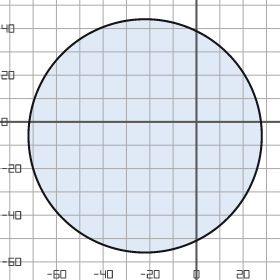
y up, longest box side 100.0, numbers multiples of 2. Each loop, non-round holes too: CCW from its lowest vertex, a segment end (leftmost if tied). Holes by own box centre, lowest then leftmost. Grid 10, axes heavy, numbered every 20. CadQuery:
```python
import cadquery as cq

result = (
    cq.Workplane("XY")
    .moveTo(-22.0, -6.0)
    .circle(50.0)
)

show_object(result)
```